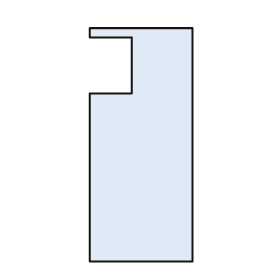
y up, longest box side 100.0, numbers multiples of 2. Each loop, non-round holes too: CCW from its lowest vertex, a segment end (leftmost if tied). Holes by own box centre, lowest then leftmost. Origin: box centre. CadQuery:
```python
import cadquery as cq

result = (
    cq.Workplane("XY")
    .moveTo(-22.0, -50.0)
    .lineTo(22.0, -50.0)
    .lineTo(22.0, 50.0)
    .lineTo(-22.0, 50.0)
    .lineTo(-22.0, 46.0)
    .lineTo(-4.0, 46.0)
    .lineTo(-4.0, 22.0)
    .lineTo(-22.0, 22.0)
    .close()
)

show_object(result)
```